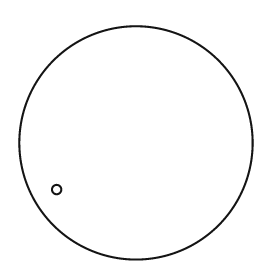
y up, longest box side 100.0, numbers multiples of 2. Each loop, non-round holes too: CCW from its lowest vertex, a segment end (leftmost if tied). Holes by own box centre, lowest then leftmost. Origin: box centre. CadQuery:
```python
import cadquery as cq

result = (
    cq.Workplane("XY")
    .moveTo(0.0, 0.0)
    .circle(50.0)
    .moveTo(-34.0, -20.0)
    .circle(2.0)
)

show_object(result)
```